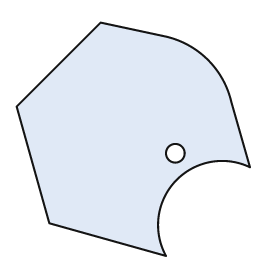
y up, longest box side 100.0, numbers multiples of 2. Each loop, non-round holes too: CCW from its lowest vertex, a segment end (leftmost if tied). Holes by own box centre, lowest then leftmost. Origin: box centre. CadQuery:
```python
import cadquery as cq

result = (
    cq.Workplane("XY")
    .moveTo(14.0, -50.0)
    .threePointArc((18.0, -18.0), (50.0, -12.0))
    .lineTo(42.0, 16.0)
    .threePointArc((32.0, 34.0), (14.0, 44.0))
    .lineTo(-14.0, 50.0)
    .lineTo(-50.0, 14.0)
    .lineTo(-36.0, -36.0)
    .close()
    .moveTo(18.0, -6.0)
    .circle(4.0)
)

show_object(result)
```